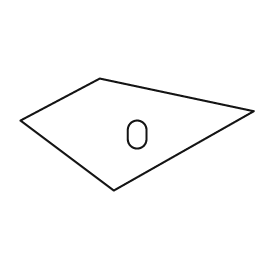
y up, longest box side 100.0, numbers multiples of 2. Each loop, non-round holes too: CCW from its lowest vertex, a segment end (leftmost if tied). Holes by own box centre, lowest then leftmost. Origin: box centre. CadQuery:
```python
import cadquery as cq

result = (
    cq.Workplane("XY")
    .moveTo(-10.0, -24.0)
    .lineTo(50.0, 10.0)
    .lineTo(-16.0, 24.0)
    .lineTo(-50.0, 6.0)
    .close()
    .moveTo(-4.0, -2.0)
    .threePointArc((0.0, -6.0), (4.0, -2.0))
    .lineTo(4.0, 2.0)
    .threePointArc((0.0, 6.0), (-4.0, 2.0))
    .close()
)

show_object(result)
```